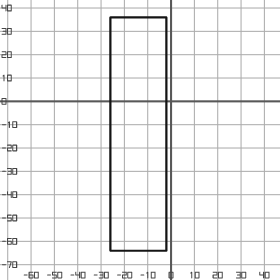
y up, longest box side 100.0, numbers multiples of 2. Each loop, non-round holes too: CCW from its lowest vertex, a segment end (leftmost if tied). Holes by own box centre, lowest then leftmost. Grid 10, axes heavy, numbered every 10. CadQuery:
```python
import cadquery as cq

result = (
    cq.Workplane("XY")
    .moveTo(-26.0, -64.0)
    .lineTo(-2.0, -64.0)
    .lineTo(-2.0, 36.0)
    .lineTo(-26.0, 36.0)
    .close()
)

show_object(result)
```